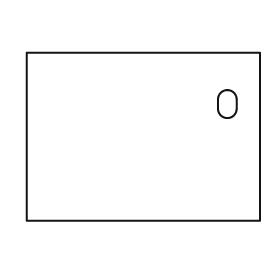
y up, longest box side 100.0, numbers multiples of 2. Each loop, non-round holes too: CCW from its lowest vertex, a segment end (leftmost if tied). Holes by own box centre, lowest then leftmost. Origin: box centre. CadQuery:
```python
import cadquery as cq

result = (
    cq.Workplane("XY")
    .moveTo(-50.0, -36.0)
    .lineTo(50.0, -36.0)
    .lineTo(50.0, 36.0)
    .lineTo(-50.0, 36.0)
    .close()
    .moveTo(32.0, 12.0)
    .threePointArc((36.0, 8.0), (40.0, 12.0))
    .lineTo(40.0, 16.0)
    .threePointArc((36.0, 20.0), (32.0, 16.0))
    .close()
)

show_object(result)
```